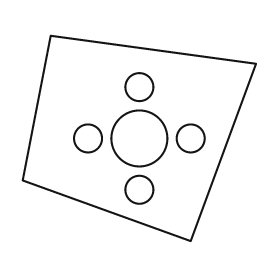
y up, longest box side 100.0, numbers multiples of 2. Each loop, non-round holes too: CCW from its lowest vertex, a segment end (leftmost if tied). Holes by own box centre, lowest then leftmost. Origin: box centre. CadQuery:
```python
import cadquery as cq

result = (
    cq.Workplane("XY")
    .moveTo(22.0, -44.0)
    .lineTo(50.0, 32.0)
    .lineTo(-38.0, 44.0)
    .lineTo(-50.0, -18.0)
    .close()
    .moveTo(0.0, -22.0)
    .circle(6.0)
    .moveTo(-22.0, 0.0)
    .circle(6.0)
    .moveTo(0.0, 0.0)
    .circle(12.0)
    .moveTo(22.0, 0.0)
    .circle(6.0)
    .moveTo(0.0, 22.0)
    .circle(6.0)
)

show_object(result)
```